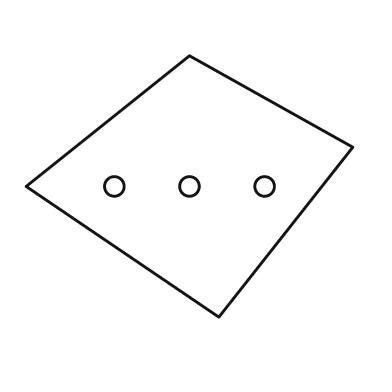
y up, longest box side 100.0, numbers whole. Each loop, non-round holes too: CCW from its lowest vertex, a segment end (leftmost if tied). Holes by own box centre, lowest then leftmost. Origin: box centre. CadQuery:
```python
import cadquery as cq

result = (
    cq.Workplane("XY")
    .moveTo(9.0, -40.0)
    .lineTo(50.0, 12.0)
    .lineTo(0.0, 40.0)
    .lineTo(-50.0, 0.0)
    .close()
    .moveTo(-23.0, 0.0)
    .circle(3.0)
    .moveTo(0.0, 0.0)
    .circle(3.0)
    .moveTo(23.0, 0.0)
    .circle(3.0)
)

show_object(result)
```